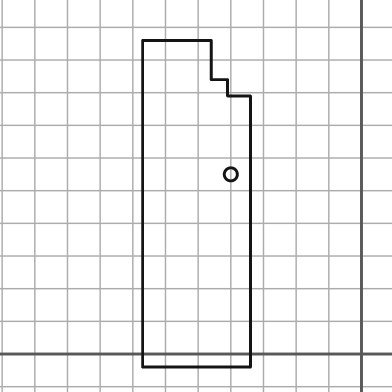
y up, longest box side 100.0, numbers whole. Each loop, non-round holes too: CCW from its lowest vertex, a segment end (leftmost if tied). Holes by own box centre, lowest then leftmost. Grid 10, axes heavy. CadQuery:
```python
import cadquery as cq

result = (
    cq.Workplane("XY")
    .moveTo(-67.0, -4.0)
    .lineTo(-34.0, -4.0)
    .lineTo(-34.0, 79.0)
    .lineTo(-41.0, 79.0)
    .lineTo(-41.0, 84.0)
    .lineTo(-46.0, 84.0)
    .lineTo(-46.0, 96.0)
    .lineTo(-67.0, 96.0)
    .close()
    .moveTo(-40.0, 55.0)
    .circle(2.0)
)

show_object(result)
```